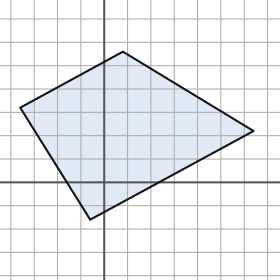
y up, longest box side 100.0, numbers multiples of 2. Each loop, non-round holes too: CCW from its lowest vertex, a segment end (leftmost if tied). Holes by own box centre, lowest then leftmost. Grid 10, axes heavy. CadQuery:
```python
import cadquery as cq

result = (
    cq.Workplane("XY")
    .moveTo(-6.0, -16.0)
    .lineTo(64.0, 22.0)
    .lineTo(8.0, 56.0)
    .lineTo(-36.0, 32.0)
    .close()
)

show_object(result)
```